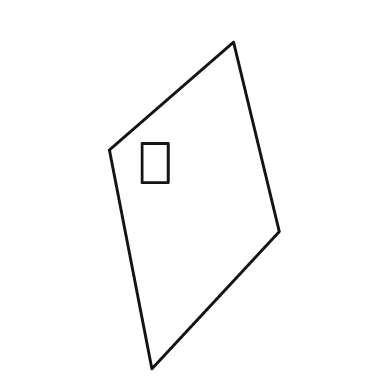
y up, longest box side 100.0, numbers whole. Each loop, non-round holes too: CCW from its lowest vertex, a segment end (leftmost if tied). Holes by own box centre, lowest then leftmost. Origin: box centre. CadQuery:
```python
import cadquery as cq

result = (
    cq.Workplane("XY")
    .moveTo(-13.0, -50.0)
    .lineTo(26.0, -8.0)
    .lineTo(12.0, 50.0)
    .lineTo(-26.0, 17.0)
    .close()
    .moveTo(-16.0, 7.0)
    .lineTo(-8.0, 7.0)
    .lineTo(-8.0, 19.0)
    .lineTo(-16.0, 19.0)
    .close()
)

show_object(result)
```